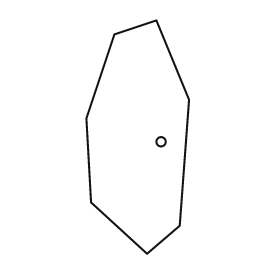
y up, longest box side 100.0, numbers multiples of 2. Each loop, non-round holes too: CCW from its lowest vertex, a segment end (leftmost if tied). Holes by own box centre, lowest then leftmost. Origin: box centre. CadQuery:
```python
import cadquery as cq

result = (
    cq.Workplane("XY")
    .moveTo(4.0, -50.0)
    .lineTo(18.0, -38.0)
    .lineTo(22.0, 16.0)
    .lineTo(8.0, 50.0)
    .lineTo(-10.0, 44.0)
    .lineTo(-22.0, 8.0)
    .lineTo(-20.0, -28.0)
    .close()
    .moveTo(10.0, -2.0)
    .circle(2.0)
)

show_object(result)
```